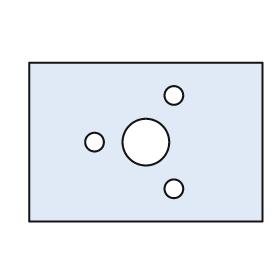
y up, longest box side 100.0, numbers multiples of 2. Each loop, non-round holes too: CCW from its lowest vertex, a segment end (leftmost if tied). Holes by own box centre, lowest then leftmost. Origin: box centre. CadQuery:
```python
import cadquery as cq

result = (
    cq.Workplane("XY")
    .moveTo(-50.0, -34.0)
    .lineTo(50.0, -34.0)
    .lineTo(50.0, 34.0)
    .lineTo(-50.0, 34.0)
    .close()
    .moveTo(12.0, -20.0)
    .circle(4.0)
    .moveTo(-22.0, 0.0)
    .circle(4.0)
    .moveTo(0.0, 0.0)
    .circle(10.0)
    .moveTo(12.0, 20.0)
    .circle(4.0)
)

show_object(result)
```